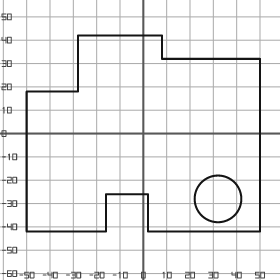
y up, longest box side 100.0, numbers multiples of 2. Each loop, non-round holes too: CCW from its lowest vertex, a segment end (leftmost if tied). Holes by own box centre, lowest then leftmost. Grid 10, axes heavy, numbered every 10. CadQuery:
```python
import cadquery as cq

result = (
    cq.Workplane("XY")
    .moveTo(-50.0, -42.0)
    .lineTo(-16.0, -42.0)
    .lineTo(-16.0, -26.0)
    .lineTo(2.0, -26.0)
    .lineTo(2.0, -42.0)
    .lineTo(50.0, -42.0)
    .lineTo(50.0, 32.0)
    .lineTo(8.0, 32.0)
    .lineTo(8.0, 42.0)
    .lineTo(-28.0, 42.0)
    .lineTo(-28.0, 18.0)
    .lineTo(-50.0, 18.0)
    .close()
    .moveTo(32.0, -28.0)
    .circle(10.0)
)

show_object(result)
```